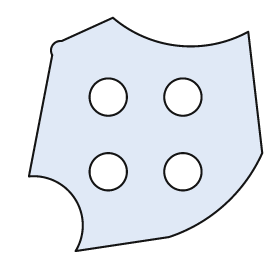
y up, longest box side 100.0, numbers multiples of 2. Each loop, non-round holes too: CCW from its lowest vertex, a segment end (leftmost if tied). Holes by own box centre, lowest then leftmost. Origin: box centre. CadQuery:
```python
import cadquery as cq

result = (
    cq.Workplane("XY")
    .moveTo(-30.0, -50.0)
    .lineTo(10.0, -44.0)
    .threePointArc((34.0, -30.0), (50.0, -8.0))
    .lineTo(44.0, 44.0)
    .threePointArc((14.0, 38.0), (-14.0, 50.0))
    .lineTo(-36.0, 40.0)
    .threePointArc((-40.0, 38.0), (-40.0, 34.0))
    .lineTo(-50.0, -18.0)
    .threePointArc((-30.0, -28.0), (-30.0, -50.0))
    .close()
    .moveTo(-16.0, -16.0)
    .circle(8.0)
    .moveTo(16.0, -16.0)
    .circle(8.0)
    .moveTo(-16.0, 16.0)
    .circle(8.0)
    .moveTo(16.0, 16.0)
    .circle(8.0)
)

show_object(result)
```